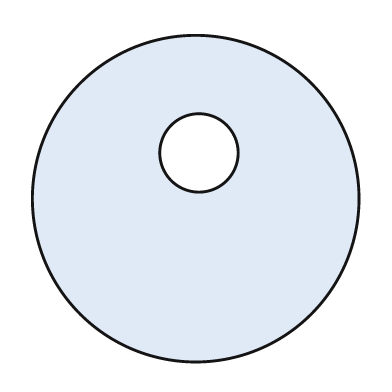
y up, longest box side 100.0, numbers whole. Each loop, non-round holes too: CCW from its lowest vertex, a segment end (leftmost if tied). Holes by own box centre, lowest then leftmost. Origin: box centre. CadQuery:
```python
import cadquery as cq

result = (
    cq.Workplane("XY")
    .moveTo(0.0, 0.0)
    .circle(50.0)
    .moveTo(1.0, 14.0)
    .circle(12.0)
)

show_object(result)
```